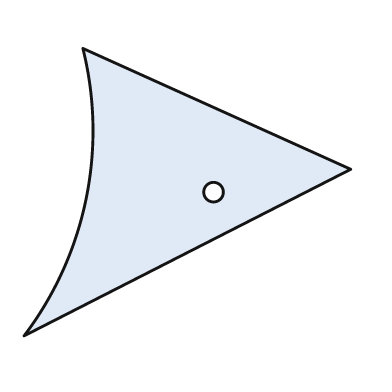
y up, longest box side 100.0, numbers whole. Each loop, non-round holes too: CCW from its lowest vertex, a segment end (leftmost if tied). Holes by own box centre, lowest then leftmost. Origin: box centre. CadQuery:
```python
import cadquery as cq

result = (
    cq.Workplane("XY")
    .moveTo(-50.0, -44.0)
    .lineTo(50.0, 7.0)
    .lineTo(-32.0, 44.0)
    .threePointArc((-31.0, -2.0), (-50.0, -44.0))
    .close()
    .moveTo(8.0, 0.0)
    .circle(3.0)
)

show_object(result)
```